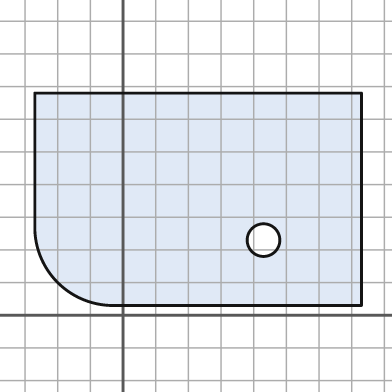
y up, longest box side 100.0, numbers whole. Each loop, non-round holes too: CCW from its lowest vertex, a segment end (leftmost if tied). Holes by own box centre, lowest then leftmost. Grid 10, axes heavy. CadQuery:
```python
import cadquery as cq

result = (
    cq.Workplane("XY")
    .moveTo(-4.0, 3.0)
    .lineTo(73.0, 3.0)
    .lineTo(73.0, 68.0)
    .lineTo(-27.0, 68.0)
    .lineTo(-27.0, 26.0)
    .threePointArc((-20.0, 10.0), (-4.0, 3.0))
    .close()
    .moveTo(43.0, 23.0)
    .circle(5.0)
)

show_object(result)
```